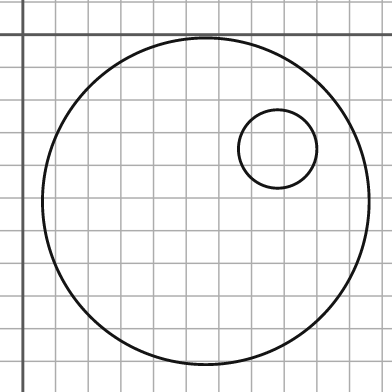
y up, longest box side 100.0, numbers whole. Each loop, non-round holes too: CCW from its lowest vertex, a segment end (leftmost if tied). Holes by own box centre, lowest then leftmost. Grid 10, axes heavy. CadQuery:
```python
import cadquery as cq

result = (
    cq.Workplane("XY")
    .moveTo(56.0, -51.0)
    .circle(50.0)
    .moveTo(78.0, -35.0)
    .circle(12.0)
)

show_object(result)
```